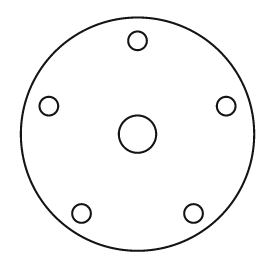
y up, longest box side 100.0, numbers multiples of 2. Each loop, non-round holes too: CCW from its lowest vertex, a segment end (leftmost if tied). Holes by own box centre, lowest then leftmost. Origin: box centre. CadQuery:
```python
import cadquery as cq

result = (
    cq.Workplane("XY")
    .moveTo(0.0, 0.0)
    .circle(50.0)
    .moveTo(-24.0, -34.0)
    .circle(4.0)
    .moveTo(24.0, -34.0)
    .circle(4.0)
    .moveTo(0.0, 0.0)
    .circle(8.0)
    .moveTo(-38.0, 12.0)
    .circle(4.0)
    .moveTo(38.0, 12.0)
    .circle(4.0)
    .moveTo(0.0, 40.0)
    .circle(4.0)
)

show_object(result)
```